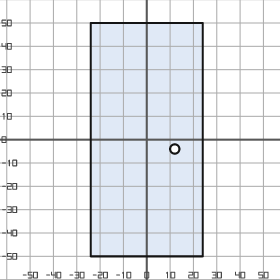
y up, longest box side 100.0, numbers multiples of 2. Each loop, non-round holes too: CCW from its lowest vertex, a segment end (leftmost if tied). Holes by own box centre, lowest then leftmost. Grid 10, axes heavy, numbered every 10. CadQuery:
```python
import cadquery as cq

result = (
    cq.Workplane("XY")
    .moveTo(-24.0, -50.0)
    .lineTo(24.0, -50.0)
    .lineTo(24.0, 50.0)
    .lineTo(-24.0, 50.0)
    .close()
    .moveTo(12.0, -4.0)
    .circle(2.0)
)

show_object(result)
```